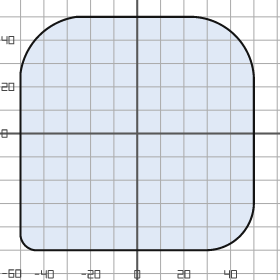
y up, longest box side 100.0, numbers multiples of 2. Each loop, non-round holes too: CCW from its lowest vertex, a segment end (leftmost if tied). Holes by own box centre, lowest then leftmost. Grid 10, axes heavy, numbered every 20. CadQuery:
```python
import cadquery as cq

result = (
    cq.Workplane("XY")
    .moveTo(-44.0, -50.0)
    .lineTo(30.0, -50.0)
    .threePointArc((44.0, -44.0), (50.0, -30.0))
    .lineTo(50.0, 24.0)
    .threePointArc((42.0, 42.0), (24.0, 50.0))
    .lineTo(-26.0, 50.0)
    .threePointArc((-42.0, 42.0), (-50.0, 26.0))
    .lineTo(-50.0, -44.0)
    .threePointArc((-48.0, -48.0), (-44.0, -50.0))
    .close()
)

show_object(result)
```